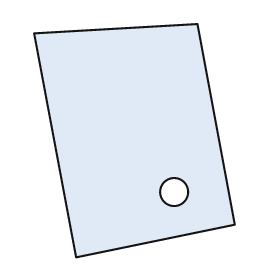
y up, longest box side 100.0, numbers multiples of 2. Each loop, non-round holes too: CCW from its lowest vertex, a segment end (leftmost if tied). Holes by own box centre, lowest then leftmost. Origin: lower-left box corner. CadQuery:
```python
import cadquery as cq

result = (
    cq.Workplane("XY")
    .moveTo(18.0, 0.0)
    .lineTo(86.0, 14.0)
    .lineTo(70.0, 100.0)
    .lineTo(0.0, 96.0)
    .close()
    .moveTo(60.0, 28.0)
    .circle(6.0)
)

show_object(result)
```